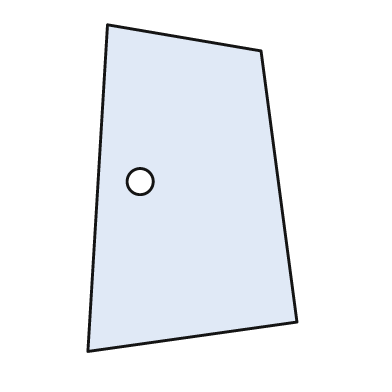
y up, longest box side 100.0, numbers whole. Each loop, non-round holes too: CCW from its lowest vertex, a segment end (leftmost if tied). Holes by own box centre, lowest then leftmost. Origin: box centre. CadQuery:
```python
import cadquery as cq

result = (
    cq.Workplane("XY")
    .moveTo(-32.0, -50.0)
    .lineTo(32.0, -41.0)
    .lineTo(21.0, 42.0)
    .lineTo(-26.0, 50.0)
    .close()
    .moveTo(-16.0, 2.0)
    .circle(4.0)
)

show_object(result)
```